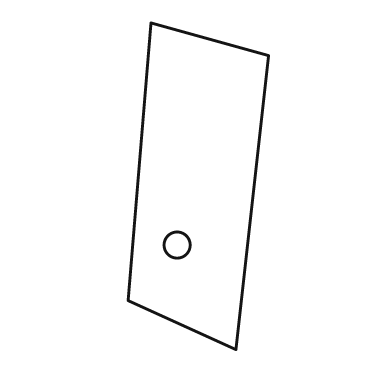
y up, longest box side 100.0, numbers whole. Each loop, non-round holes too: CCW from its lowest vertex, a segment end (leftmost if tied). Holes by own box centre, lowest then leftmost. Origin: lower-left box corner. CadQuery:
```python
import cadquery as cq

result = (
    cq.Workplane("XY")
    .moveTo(33.0, 0.0)
    .lineTo(43.0, 90.0)
    .lineTo(7.0, 100.0)
    .lineTo(0.0, 15.0)
    .close()
    .moveTo(15.0, 32.0)
    .circle(4.0)
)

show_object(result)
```